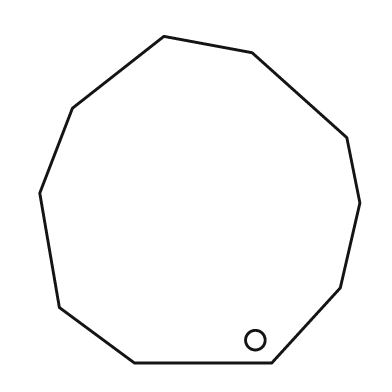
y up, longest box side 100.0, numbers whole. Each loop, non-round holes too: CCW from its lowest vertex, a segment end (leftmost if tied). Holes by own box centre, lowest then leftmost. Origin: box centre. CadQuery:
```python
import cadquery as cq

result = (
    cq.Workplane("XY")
    .moveTo(-20.0, -50.0)
    .lineTo(22.0, -50.0)
    .lineTo(43.0, -27.0)
    .lineTo(49.0, -1.0)
    .lineTo(45.0, 19.0)
    .lineTo(16.0, 45.0)
    .lineTo(-11.0, 50.0)
    .lineTo(-39.0, 28.0)
    .lineTo(-49.0, 2.0)
    .lineTo(-43.0, -33.0)
    .close()
    .moveTo(17.0, -43.0)
    .circle(3.0)
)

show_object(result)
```